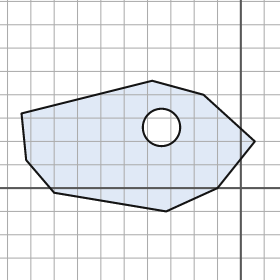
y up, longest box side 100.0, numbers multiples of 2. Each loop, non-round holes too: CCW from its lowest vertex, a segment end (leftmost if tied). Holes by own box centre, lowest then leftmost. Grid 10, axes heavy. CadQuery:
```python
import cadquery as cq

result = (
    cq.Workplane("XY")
    .moveTo(-32.0, -10.0)
    .lineTo(-10.0, 0.0)
    .lineTo(6.0, 20.0)
    .lineTo(-16.0, 40.0)
    .lineTo(-38.0, 46.0)
    .lineTo(-94.0, 32.0)
    .lineTo(-92.0, 12.0)
    .lineTo(-80.0, -2.0)
    .close()
    .moveTo(-34.0, 26.0)
    .circle(8.0)
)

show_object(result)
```